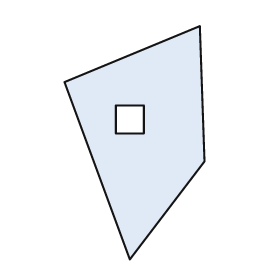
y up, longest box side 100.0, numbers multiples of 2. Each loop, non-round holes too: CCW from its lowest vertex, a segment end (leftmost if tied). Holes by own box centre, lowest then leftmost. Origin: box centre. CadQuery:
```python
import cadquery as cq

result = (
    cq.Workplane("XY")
    .moveTo(-2.0, -50.0)
    .lineTo(30.0, -8.0)
    .lineTo(28.0, 50.0)
    .lineTo(-30.0, 26.0)
    .close()
    .moveTo(-8.0, 4.0)
    .lineTo(4.0, 4.0)
    .lineTo(4.0, 16.0)
    .lineTo(-8.0, 16.0)
    .close()
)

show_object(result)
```